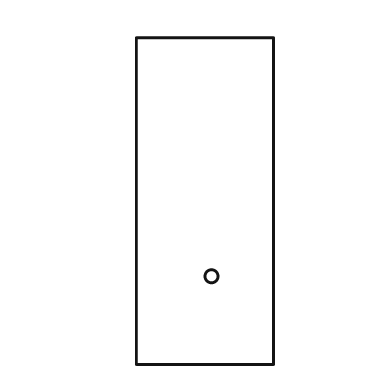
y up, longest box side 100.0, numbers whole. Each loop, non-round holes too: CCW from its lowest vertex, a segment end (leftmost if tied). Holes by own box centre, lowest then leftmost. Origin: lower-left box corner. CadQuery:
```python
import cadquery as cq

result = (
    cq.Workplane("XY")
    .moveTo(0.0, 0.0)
    .lineTo(42.0, 0.0)
    .lineTo(42.0, 100.0)
    .lineTo(0.0, 100.0)
    .close()
    .moveTo(23.0, 27.0)
    .circle(2.0)
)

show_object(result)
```